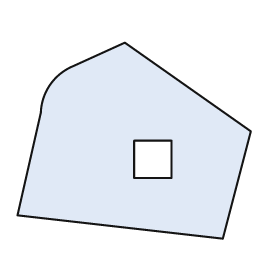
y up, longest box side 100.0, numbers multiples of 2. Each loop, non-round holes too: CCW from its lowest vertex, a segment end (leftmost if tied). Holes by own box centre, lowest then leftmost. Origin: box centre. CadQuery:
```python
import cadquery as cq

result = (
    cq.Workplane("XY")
    .moveTo(38.0, -42.0)
    .lineTo(50.0, 4.0)
    .lineTo(-4.0, 42.0)
    .lineTo(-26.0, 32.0)
    .threePointArc((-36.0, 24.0), (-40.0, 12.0))
    .lineTo(-50.0, -32.0)
    .close()
    .moveTo(0.0, -16.0)
    .lineTo(16.0, -16.0)
    .lineTo(16.0, 0.0)
    .lineTo(0.0, 0.0)
    .close()
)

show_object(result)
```